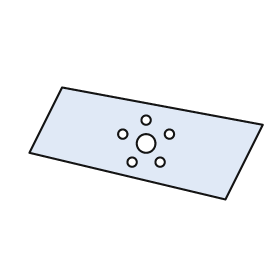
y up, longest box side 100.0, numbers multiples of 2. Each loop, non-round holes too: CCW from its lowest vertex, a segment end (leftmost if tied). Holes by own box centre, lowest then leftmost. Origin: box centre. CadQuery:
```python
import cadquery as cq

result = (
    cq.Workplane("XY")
    .moveTo(34.0, -24.0)
    .lineTo(50.0, 8.0)
    .lineTo(-36.0, 24.0)
    .lineTo(-50.0, -4.0)
    .close()
    .moveTo(-6.0, -8.0)
    .circle(2.0)
    .moveTo(6.0, -8.0)
    .circle(2.0)
    .moveTo(0.0, 0.0)
    .circle(4.0)
    .moveTo(-10.0, 4.0)
    .circle(2.0)
    .moveTo(10.0, 4.0)
    .circle(2.0)
    .moveTo(0.0, 10.0)
    .circle(2.0)
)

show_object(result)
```